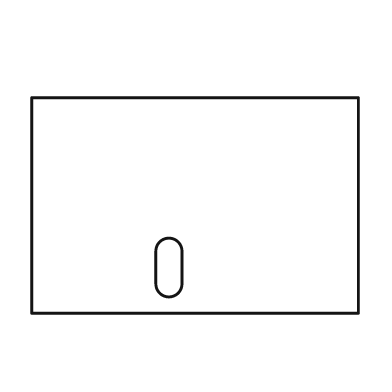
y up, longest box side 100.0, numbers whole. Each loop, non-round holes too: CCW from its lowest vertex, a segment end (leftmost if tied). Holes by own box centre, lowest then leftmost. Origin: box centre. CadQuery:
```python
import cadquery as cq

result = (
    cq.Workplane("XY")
    .moveTo(-50.0, -33.0)
    .lineTo(50.0, -33.0)
    .lineTo(50.0, 33.0)
    .lineTo(-50.0, 33.0)
    .close()
    .moveTo(-12.0, -24.0)
    .threePointArc((-8.0, -28.0), (-4.0, -24.0))
    .lineTo(-4.0, -14.0)
    .threePointArc((-8.0, -10.0), (-12.0, -14.0))
    .close()
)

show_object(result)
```